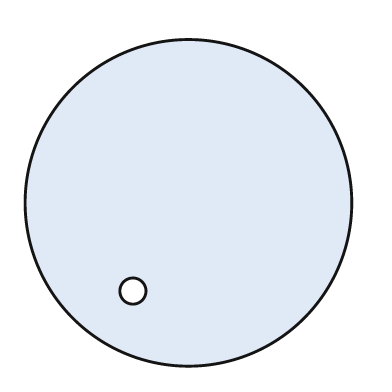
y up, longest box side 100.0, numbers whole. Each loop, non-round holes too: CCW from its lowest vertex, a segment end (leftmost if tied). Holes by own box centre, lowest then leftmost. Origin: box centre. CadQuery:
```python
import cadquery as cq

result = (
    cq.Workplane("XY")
    .moveTo(0.0, 0.0)
    .circle(50.0)
    .moveTo(-17.0, -27.0)
    .circle(4.0)
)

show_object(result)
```